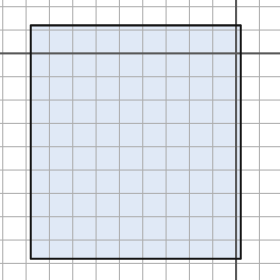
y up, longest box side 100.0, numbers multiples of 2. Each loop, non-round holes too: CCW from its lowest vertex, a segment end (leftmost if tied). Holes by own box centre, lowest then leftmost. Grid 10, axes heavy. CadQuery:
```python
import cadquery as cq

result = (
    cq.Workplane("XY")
    .moveTo(-88.0, -88.0)
    .lineTo(2.0, -88.0)
    .lineTo(2.0, 12.0)
    .lineTo(-88.0, 12.0)
    .close()
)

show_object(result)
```